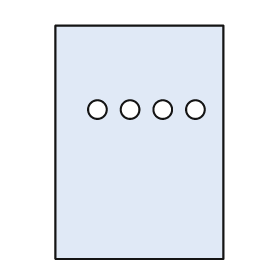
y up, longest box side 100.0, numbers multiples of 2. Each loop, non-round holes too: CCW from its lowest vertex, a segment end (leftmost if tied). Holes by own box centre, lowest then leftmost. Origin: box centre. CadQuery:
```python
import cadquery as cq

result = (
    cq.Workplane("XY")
    .moveTo(-36.0, -50.0)
    .lineTo(36.0, -50.0)
    .lineTo(36.0, 50.0)
    .lineTo(-36.0, 50.0)
    .close()
    .moveTo(-18.0, 14.0)
    .circle(4.0)
    .moveTo(-4.0, 14.0)
    .circle(4.0)
    .moveTo(10.0, 14.0)
    .circle(4.0)
    .moveTo(24.0, 14.0)
    .circle(4.0)
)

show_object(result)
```